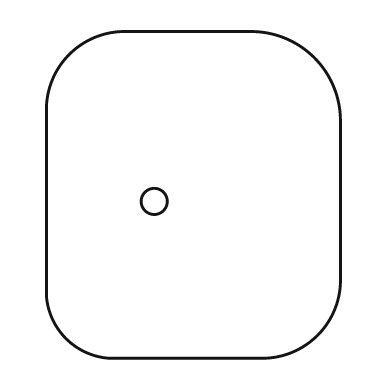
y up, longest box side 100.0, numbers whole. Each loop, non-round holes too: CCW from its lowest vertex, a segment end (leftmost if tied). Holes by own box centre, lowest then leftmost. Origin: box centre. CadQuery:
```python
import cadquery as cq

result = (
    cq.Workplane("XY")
    .moveTo(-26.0, -50.0)
    .lineTo(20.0, -50.0)
    .threePointArc((38.0, -43.0), (45.0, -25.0))
    .lineTo(45.0, 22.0)
    .threePointArc((37.0, 42.0), (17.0, 50.0))
    .lineTo(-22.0, 50.0)
    .threePointArc((-38.0, 43.0), (-45.0, 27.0))
    .lineTo(-45.0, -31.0)
    .threePointArc((-39.0, -44.0), (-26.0, -50.0))
    .close()
    .moveTo(-12.0, -2.0)
    .circle(4.0)
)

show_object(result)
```